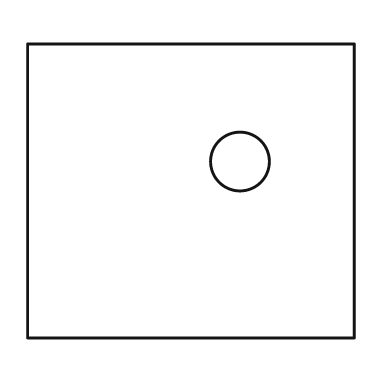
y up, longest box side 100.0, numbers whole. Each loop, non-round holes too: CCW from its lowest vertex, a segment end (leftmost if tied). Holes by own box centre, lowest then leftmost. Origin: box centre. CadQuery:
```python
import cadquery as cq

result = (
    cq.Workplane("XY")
    .moveTo(-50.0, -45.0)
    .lineTo(50.0, -45.0)
    .lineTo(50.0, 45.0)
    .lineTo(-50.0, 45.0)
    .close()
    .moveTo(15.0, 9.0)
    .circle(9.0)
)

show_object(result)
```